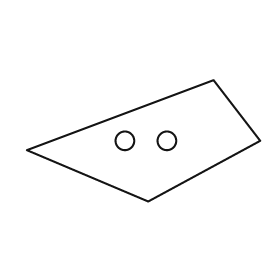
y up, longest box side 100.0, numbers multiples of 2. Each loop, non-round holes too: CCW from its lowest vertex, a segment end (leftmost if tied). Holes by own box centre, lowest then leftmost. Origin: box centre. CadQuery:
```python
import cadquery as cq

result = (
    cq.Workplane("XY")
    .moveTo(2.0, -26.0)
    .lineTo(50.0, 0.0)
    .lineTo(30.0, 26.0)
    .lineTo(-50.0, -4.0)
    .close()
    .moveTo(-8.0, 0.0)
    .circle(4.0)
    .moveTo(10.0, 0.0)
    .circle(4.0)
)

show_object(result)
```